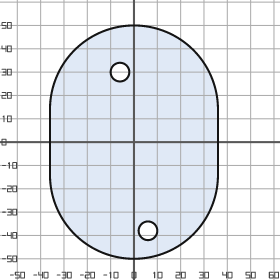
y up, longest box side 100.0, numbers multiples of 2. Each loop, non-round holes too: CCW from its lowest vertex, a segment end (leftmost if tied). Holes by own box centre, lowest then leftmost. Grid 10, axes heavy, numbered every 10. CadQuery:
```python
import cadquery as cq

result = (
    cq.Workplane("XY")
    .moveTo(-36.0, -14.0)
    .threePointArc((0.0, -50.0), (36.0, -14.0))
    .lineTo(36.0, 14.0)
    .threePointArc((0.0, 50.0), (-36.0, 14.0))
    .close()
    .moveTo(6.0, -38.0)
    .circle(4.0)
    .moveTo(-6.0, 30.0)
    .circle(4.0)
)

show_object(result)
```